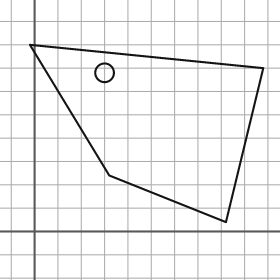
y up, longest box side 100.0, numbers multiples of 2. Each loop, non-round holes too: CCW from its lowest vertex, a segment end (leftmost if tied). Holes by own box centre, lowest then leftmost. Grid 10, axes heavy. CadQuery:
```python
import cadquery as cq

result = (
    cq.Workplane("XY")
    .moveTo(82.0, 4.0)
    .lineTo(98.0, 70.0)
    .lineTo(-2.0, 80.0)
    .lineTo(32.0, 24.0)
    .close()
    .moveTo(30.0, 68.0)
    .circle(4.0)
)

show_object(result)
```